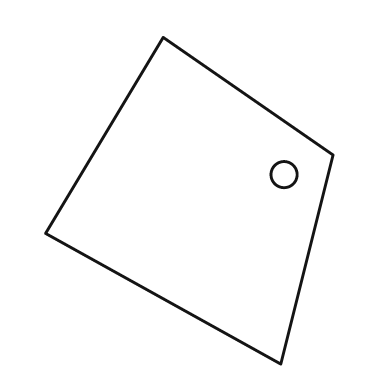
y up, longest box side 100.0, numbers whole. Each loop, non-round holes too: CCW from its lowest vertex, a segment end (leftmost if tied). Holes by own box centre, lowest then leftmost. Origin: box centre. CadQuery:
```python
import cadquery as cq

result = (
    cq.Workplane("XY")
    .moveTo(28.0, -50.0)
    .lineTo(44.0, 14.0)
    .lineTo(-8.0, 50.0)
    .lineTo(-44.0, -10.0)
    .close()
    .moveTo(29.0, 8.0)
    .circle(4.0)
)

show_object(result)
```